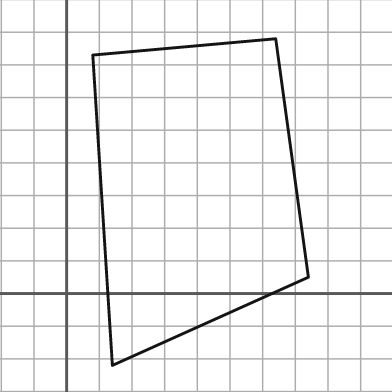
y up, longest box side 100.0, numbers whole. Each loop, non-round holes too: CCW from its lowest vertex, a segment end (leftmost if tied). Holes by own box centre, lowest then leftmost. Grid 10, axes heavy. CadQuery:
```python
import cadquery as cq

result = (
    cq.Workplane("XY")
    .moveTo(14.0, -22.0)
    .lineTo(74.0, 5.0)
    .lineTo(64.0, 78.0)
    .lineTo(8.0, 73.0)
    .close()
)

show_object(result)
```